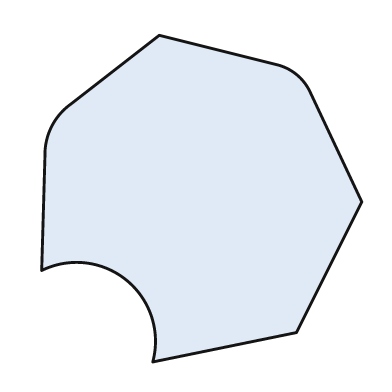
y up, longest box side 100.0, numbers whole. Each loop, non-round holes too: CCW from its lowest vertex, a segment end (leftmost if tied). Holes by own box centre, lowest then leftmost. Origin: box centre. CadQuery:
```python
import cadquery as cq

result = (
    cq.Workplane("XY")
    .moveTo(-15.0, -50.0)
    .lineTo(29.0, -41.0)
    .lineTo(49.0, -1.0)
    .lineTo(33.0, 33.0)
    .threePointArc((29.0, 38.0), (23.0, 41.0))
    .lineTo(-13.0, 50.0)
    .lineTo(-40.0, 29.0)
    .threePointArc((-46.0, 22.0), (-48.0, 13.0))
    .lineTo(-49.0, -22.0)
    .threePointArc((-23.0, -25.0), (-15.0, -50.0))
    .close()
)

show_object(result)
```